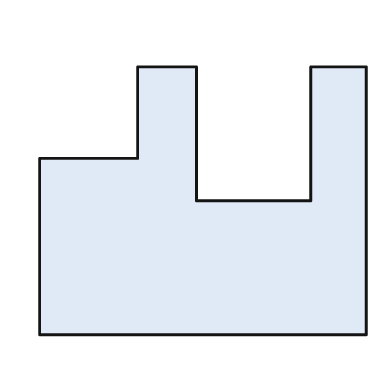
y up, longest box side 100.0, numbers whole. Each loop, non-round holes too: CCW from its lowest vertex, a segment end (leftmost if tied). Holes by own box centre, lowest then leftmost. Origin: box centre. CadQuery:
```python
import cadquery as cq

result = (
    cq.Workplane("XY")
    .moveTo(-50.0, -41.0)
    .lineTo(50.0, -41.0)
    .lineTo(50.0, 41.0)
    .lineTo(33.0, 41.0)
    .lineTo(33.0, 0.0)
    .lineTo(-2.0, 0.0)
    .lineTo(-2.0, 41.0)
    .lineTo(-20.0, 41.0)
    .lineTo(-20.0, 13.0)
    .lineTo(-50.0, 13.0)
    .close()
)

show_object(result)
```